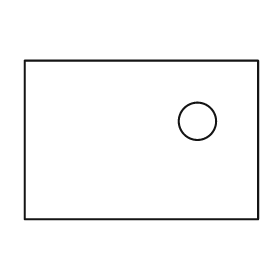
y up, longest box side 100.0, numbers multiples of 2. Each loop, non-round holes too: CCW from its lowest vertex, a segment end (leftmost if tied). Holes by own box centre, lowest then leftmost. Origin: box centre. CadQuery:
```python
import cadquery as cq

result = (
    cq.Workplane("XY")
    .moveTo(-50.0, -34.0)
    .lineTo(50.0, -34.0)
    .lineTo(50.0, 34.0)
    .lineTo(-50.0, 34.0)
    .close()
    .moveTo(24.0, 8.0)
    .circle(8.0)
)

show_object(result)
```